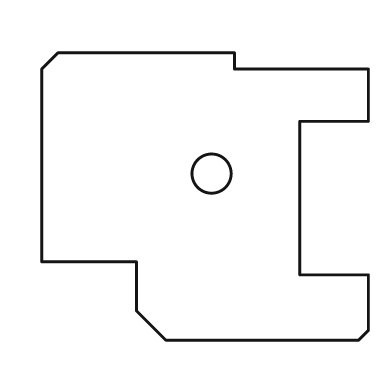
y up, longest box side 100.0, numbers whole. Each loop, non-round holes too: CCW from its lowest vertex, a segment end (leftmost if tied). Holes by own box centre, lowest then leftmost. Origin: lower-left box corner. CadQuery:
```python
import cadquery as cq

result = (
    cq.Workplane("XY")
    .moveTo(38.0, 0.0)
    .lineTo(97.0, 0.0)
    .lineTo(100.0, 3.0)
    .lineTo(100.0, 20.0)
    .lineTo(79.0, 20.0)
    .lineTo(79.0, 67.0)
    .lineTo(100.0, 67.0)
    .lineTo(100.0, 83.0)
    .lineTo(59.0, 83.0)
    .lineTo(59.0, 88.0)
    .lineTo(5.0, 88.0)
    .lineTo(0.0, 83.0)
    .lineTo(0.0, 24.0)
    .lineTo(29.0, 24.0)
    .lineTo(29.0, 9.0)
    .close()
    .moveTo(52.0, 51.0)
    .circle(6.0)
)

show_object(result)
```